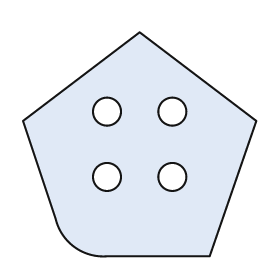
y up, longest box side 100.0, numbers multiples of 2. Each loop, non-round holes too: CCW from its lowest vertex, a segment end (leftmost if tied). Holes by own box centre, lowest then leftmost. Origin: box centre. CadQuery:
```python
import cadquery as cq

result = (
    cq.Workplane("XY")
    .moveTo(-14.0, -48.0)
    .lineTo(30.0, -48.0)
    .lineTo(50.0, 10.0)
    .lineTo(0.0, 48.0)
    .lineTo(-50.0, 10.0)
    .lineTo(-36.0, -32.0)
    .threePointArc((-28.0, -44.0), (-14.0, -48.0))
    .close()
    .moveTo(-14.0, -14.0)
    .circle(6.0)
    .moveTo(14.0, -14.0)
    .circle(6.0)
    .moveTo(-14.0, 14.0)
    .circle(6.0)
    .moveTo(14.0, 14.0)
    .circle(6.0)
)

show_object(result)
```